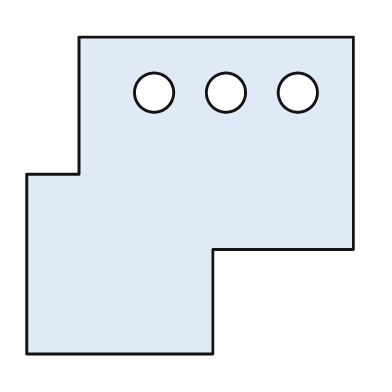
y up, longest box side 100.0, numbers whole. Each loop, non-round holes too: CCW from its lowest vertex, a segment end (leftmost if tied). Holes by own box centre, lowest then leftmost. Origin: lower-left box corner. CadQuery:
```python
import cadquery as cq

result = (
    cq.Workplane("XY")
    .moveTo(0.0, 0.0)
    .lineTo(57.0, 0.0)
    .lineTo(57.0, 32.0)
    .lineTo(100.0, 32.0)
    .lineTo(100.0, 97.0)
    .lineTo(16.0, 97.0)
    .lineTo(16.0, 55.0)
    .lineTo(0.0, 55.0)
    .close()
    .moveTo(39.0, 80.0)
    .circle(6.0)
    .moveTo(61.0, 80.0)
    .circle(6.0)
    .moveTo(83.0, 80.0)
    .circle(6.0)
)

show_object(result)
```